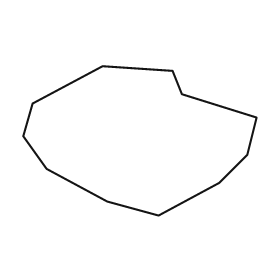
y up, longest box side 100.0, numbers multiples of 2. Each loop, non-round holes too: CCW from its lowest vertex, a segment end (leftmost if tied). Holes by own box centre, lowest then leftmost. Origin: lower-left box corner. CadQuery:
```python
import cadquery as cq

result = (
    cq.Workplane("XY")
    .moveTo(58.0, 0.0)
    .lineTo(84.0, 14.0)
    .lineTo(96.0, 26.0)
    .lineTo(100.0, 42.0)
    .lineTo(68.0, 52.0)
    .lineTo(64.0, 62.0)
    .lineTo(34.0, 64.0)
    .lineTo(4.0, 48.0)
    .lineTo(0.0, 34.0)
    .lineTo(10.0, 20.0)
    .lineTo(36.0, 6.0)
    .close()
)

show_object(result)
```